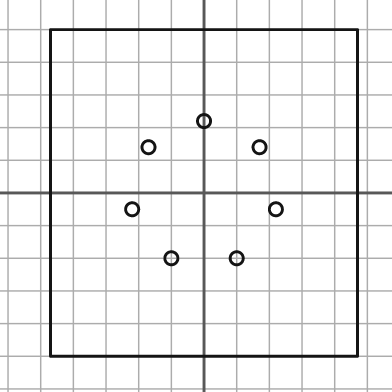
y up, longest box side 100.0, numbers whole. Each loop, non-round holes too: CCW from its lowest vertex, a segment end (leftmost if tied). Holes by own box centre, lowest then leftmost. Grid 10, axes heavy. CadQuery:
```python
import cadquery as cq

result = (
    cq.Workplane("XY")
    .moveTo(-47.0, -50.0)
    .lineTo(47.0, -50.0)
    .lineTo(47.0, 50.0)
    .lineTo(-47.0, 50.0)
    .close()
    .moveTo(-10.0, -20.0)
    .circle(2.0)
    .moveTo(10.0, -20.0)
    .circle(2.0)
    .moveTo(-22.0, -5.0)
    .circle(2.0)
    .moveTo(22.0, -5.0)
    .circle(2.0)
    .moveTo(-17.0, 14.0)
    .circle(2.0)
    .moveTo(17.0, 14.0)
    .circle(2.0)
    .moveTo(0.0, 22.0)
    .circle(2.0)
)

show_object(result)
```